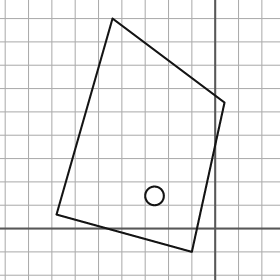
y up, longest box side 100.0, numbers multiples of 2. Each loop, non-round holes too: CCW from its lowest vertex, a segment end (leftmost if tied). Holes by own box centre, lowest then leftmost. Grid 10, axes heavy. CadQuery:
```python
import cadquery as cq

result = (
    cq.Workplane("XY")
    .moveTo(-10.0, -10.0)
    .lineTo(4.0, 54.0)
    .lineTo(-44.0, 90.0)
    .lineTo(-68.0, 6.0)
    .close()
    .moveTo(-26.0, 14.0)
    .circle(4.0)
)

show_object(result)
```